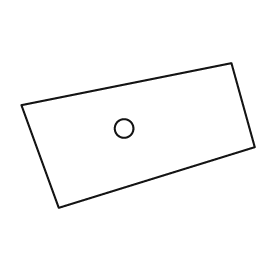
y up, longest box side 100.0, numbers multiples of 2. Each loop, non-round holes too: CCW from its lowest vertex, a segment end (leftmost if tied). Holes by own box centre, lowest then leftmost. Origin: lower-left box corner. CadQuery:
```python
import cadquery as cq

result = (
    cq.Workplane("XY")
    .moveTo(16.0, 0.0)
    .lineTo(100.0, 26.0)
    .lineTo(90.0, 62.0)
    .lineTo(0.0, 44.0)
    .close()
    .moveTo(44.0, 34.0)
    .circle(4.0)
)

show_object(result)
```